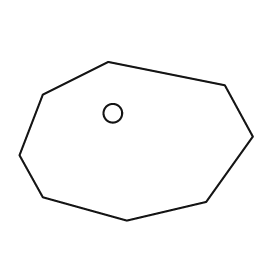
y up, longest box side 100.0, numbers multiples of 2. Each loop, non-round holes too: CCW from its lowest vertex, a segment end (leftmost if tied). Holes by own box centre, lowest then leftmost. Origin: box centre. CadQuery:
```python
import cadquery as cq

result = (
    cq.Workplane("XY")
    .moveTo(-4.0, -34.0)
    .lineTo(30.0, -26.0)
    .lineTo(50.0, 2.0)
    .lineTo(38.0, 24.0)
    .lineTo(-12.0, 34.0)
    .lineTo(-40.0, 20.0)
    .lineTo(-50.0, -6.0)
    .lineTo(-40.0, -24.0)
    .close()
    .moveTo(-10.0, 12.0)
    .circle(4.0)
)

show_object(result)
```